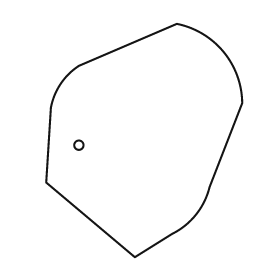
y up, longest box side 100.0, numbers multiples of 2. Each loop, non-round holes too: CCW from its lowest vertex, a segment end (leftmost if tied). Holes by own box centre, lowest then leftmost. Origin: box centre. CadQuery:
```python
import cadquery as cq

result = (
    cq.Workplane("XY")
    .moveTo(-4.0, -50.0)
    .lineTo(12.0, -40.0)
    .threePointArc((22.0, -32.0), (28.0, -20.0))
    .lineTo(42.0, 16.0)
    .threePointArc((34.0, 38.0), (14.0, 50.0))
    .lineTo(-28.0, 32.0)
    .threePointArc((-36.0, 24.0), (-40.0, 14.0))
    .lineTo(-42.0, -18.0)
    .close()
    .moveTo(-28.0, -2.0)
    .circle(2.0)
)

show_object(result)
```